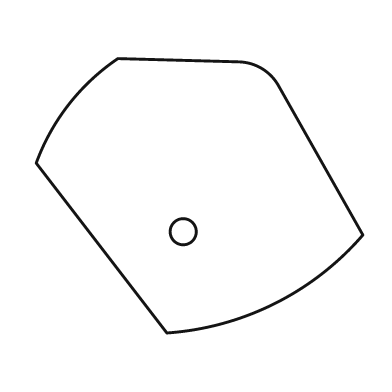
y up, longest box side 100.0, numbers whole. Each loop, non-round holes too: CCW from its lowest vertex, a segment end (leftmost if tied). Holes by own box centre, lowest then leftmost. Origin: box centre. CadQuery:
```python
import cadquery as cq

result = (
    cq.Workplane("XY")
    .moveTo(-10.0, -42.0)
    .threePointArc((23.0, -33.0), (50.0, -12.0))
    .lineTo(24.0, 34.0)
    .threePointArc((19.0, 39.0), (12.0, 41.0))
    .lineTo(-25.0, 42.0)
    .threePointArc((-40.0, 28.0), (-50.0, 10.0))
    .close()
    .moveTo(-5.0, -11.0)
    .circle(4.0)
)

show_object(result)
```